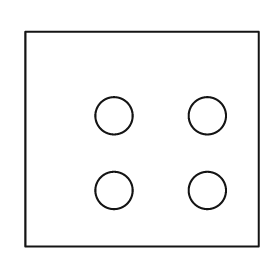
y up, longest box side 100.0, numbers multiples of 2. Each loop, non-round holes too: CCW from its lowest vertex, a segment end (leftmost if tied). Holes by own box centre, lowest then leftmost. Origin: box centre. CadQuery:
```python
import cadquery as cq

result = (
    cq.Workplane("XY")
    .moveTo(-50.0, -46.0)
    .lineTo(50.0, -46.0)
    .lineTo(50.0, 46.0)
    .lineTo(-50.0, 46.0)
    .close()
    .moveTo(-12.0, -22.0)
    .circle(8.0)
    .moveTo(28.0, -22.0)
    .circle(8.0)
    .moveTo(-12.0, 10.0)
    .circle(8.0)
    .moveTo(28.0, 10.0)
    .circle(8.0)
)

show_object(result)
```